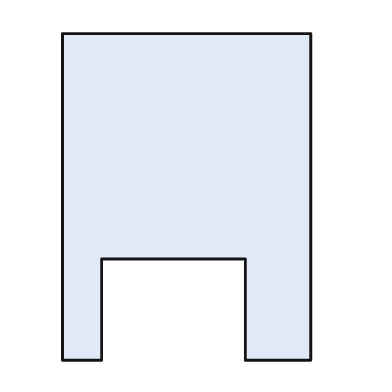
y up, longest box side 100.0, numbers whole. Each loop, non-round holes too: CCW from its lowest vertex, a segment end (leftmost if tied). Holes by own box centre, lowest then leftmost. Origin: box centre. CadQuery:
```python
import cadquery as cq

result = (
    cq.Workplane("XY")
    .moveTo(-38.0, -50.0)
    .lineTo(-26.0, -50.0)
    .lineTo(-26.0, -19.0)
    .lineTo(18.0, -19.0)
    .lineTo(18.0, -50.0)
    .lineTo(38.0, -50.0)
    .lineTo(38.0, 50.0)
    .lineTo(-38.0, 50.0)
    .close()
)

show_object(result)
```